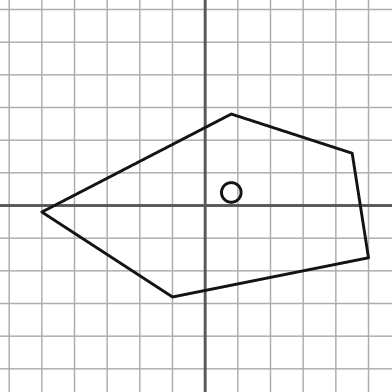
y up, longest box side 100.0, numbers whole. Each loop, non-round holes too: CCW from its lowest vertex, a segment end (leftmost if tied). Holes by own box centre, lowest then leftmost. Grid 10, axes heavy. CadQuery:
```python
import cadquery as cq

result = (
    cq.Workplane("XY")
    .moveTo(-10.0, -28.0)
    .lineTo(50.0, -16.0)
    .lineTo(45.0, 16.0)
    .lineTo(8.0, 28.0)
    .lineTo(-50.0, -2.0)
    .close()
    .moveTo(8.0, 4.0)
    .circle(3.0)
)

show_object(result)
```